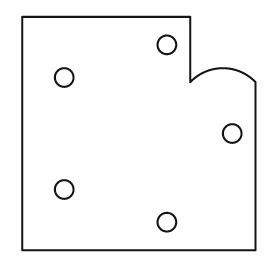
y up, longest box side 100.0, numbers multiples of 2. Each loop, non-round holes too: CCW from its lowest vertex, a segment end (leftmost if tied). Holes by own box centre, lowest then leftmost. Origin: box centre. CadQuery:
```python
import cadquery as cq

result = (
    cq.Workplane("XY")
    .moveTo(-50.0, -50.0)
    .lineTo(50.0, -50.0)
    .lineTo(50.0, 22.0)
    .threePointArc((36.0, 28.0), (22.0, 22.0))
    .lineTo(22.0, 50.0)
    .lineTo(-50.0, 50.0)
    .close()
    .moveTo(12.0, -38.0)
    .circle(4.0)
    .moveTo(-32.0, -24.0)
    .circle(4.0)
    .moveTo(40.0, 0.0)
    .circle(4.0)
    .moveTo(-32.0, 24.0)
    .circle(4.0)
    .moveTo(12.0, 38.0)
    .circle(4.0)
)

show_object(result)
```